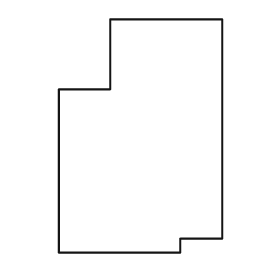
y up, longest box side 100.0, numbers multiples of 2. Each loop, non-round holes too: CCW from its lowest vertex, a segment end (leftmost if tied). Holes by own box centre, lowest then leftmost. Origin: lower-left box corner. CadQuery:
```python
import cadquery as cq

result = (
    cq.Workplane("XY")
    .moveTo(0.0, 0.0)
    .lineTo(52.0, 0.0)
    .lineTo(52.0, 6.0)
    .lineTo(70.0, 6.0)
    .lineTo(70.0, 100.0)
    .lineTo(22.0, 100.0)
    .lineTo(22.0, 70.0)
    .lineTo(0.0, 70.0)
    .close()
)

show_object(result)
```